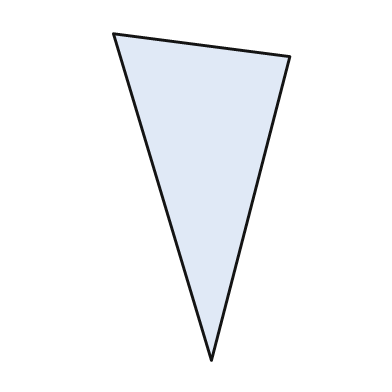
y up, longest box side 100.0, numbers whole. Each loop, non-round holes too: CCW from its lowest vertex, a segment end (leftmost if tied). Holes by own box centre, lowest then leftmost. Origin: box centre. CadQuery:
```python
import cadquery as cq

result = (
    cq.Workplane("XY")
    .moveTo(3.0, -50.0)
    .lineTo(27.0, 43.0)
    .lineTo(-27.0, 50.0)
    .close()
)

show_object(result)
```